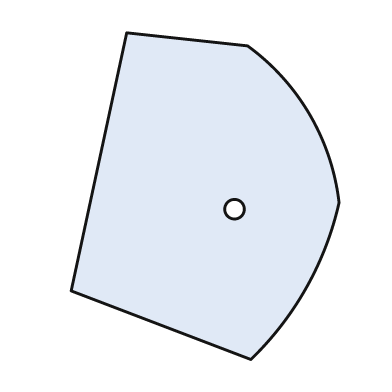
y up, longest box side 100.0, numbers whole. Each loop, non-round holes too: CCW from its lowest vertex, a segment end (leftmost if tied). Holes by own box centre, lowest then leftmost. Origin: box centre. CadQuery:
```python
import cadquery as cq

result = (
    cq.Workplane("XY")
    .moveTo(14.0, -50.0)
    .threePointArc((31.0, -28.0), (41.0, -2.0))
    .threePointArc((32.0, 25.0), (13.0, 46.0))
    .lineTo(-24.0, 50.0)
    .lineTo(-41.0, -29.0)
    .close()
    .moveTo(9.0, -4.0)
    .circle(3.0)
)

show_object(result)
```